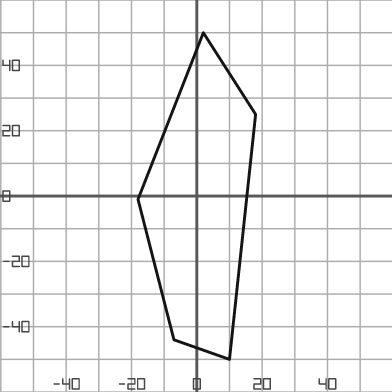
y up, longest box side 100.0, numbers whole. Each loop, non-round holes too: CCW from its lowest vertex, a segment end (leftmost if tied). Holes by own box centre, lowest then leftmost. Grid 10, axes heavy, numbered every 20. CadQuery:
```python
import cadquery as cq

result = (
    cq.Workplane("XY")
    .moveTo(10.0, -50.0)
    .lineTo(18.0, 25.0)
    .lineTo(2.0, 50.0)
    .lineTo(-18.0, -1.0)
    .lineTo(-7.0, -44.0)
    .close()
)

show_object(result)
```